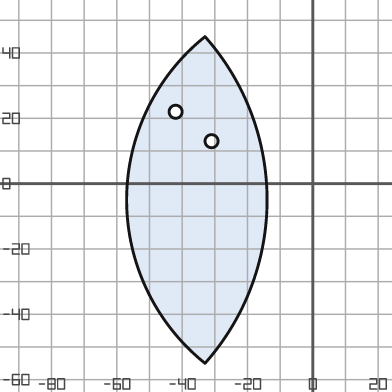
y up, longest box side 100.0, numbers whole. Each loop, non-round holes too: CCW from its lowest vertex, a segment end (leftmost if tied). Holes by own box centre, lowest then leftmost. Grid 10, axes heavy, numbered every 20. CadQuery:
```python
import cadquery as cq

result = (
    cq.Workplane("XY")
    .moveTo(-33.0, -55.0)
    .threePointArc((-14.0, -5.0), (-33.0, 45.0))
    .threePointArc((-57.0, -5.0), (-33.0, -55.0))
    .close()
    .moveTo(-31.0, 13.0)
    .circle(2.0)
    .moveTo(-42.0, 22.0)
    .circle(2.0)
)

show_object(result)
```